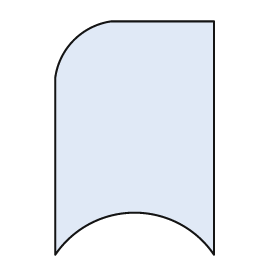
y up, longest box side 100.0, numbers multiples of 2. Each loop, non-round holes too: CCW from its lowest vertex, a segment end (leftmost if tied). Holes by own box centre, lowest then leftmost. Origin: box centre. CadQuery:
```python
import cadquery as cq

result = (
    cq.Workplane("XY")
    .moveTo(-34.0, -50.0)
    .threePointArc((0.0, -32.0), (34.0, -50.0))
    .lineTo(34.0, 50.0)
    .lineTo(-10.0, 50.0)
    .threePointArc((-26.0, 42.0), (-34.0, 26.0))
    .close()
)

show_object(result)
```